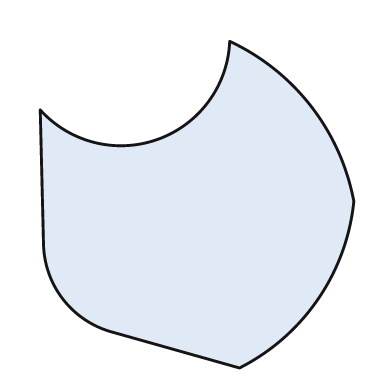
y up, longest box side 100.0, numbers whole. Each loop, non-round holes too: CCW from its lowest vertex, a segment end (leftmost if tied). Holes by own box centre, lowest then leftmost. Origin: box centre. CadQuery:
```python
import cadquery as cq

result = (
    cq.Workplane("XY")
    .moveTo(13.0, -50.0)
    .threePointArc((37.0, -29.0), (48.0, 1.0))
    .threePointArc((35.0, 30.0), (10.0, 50.0))
    .threePointArc((-12.0, 20.0), (-48.0, 29.0))
    .lineTo(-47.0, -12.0)
    .threePointArc((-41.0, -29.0), (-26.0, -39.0))
    .close()
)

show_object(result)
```